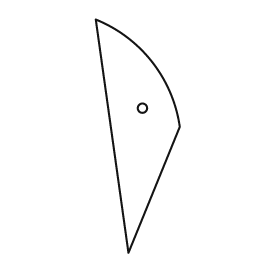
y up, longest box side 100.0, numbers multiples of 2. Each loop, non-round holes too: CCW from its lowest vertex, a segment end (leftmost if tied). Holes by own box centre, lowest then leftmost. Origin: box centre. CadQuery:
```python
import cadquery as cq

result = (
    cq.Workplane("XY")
    .moveTo(-4.0, -50.0)
    .lineTo(18.0, 4.0)
    .threePointArc((6.0, 32.0), (-18.0, 50.0))
    .close()
    .moveTo(2.0, 12.0)
    .circle(2.0)
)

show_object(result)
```